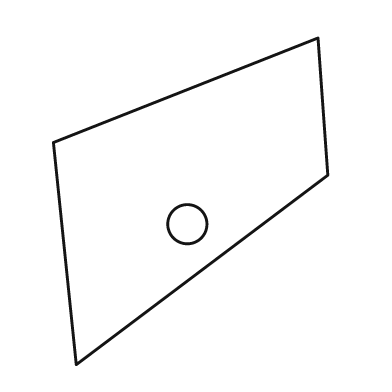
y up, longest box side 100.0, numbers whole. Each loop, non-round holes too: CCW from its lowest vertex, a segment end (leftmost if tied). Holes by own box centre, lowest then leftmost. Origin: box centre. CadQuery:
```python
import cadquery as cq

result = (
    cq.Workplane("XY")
    .moveTo(-35.0, -50.0)
    .lineTo(42.0, 8.0)
    .lineTo(39.0, 50.0)
    .lineTo(-42.0, 18.0)
    .close()
    .moveTo(-1.0, -7.0)
    .circle(6.0)
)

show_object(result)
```